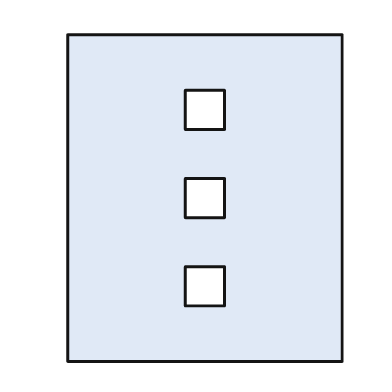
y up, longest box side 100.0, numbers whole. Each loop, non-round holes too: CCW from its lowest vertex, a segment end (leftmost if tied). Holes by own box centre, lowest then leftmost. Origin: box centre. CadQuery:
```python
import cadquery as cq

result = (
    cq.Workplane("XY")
    .moveTo(-42.0, -50.0)
    .lineTo(42.0, -50.0)
    .lineTo(42.0, 50.0)
    .lineTo(-42.0, 50.0)
    .close()
    .moveTo(-6.0, -33.0)
    .lineTo(6.0, -33.0)
    .lineTo(6.0, -21.0)
    .lineTo(-6.0, -21.0)
    .close()
    .moveTo(-6.0, -6.0)
    .lineTo(6.0, -6.0)
    .lineTo(6.0, 6.0)
    .lineTo(-6.0, 6.0)
    .close()
    .moveTo(-6.0, 21.0)
    .lineTo(6.0, 21.0)
    .lineTo(6.0, 33.0)
    .lineTo(-6.0, 33.0)
    .close()
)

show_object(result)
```